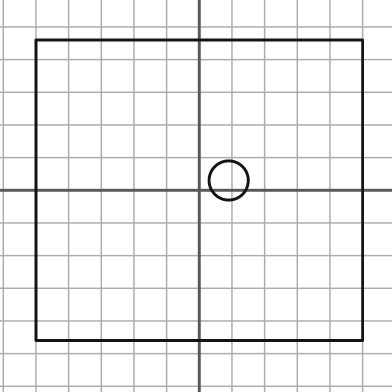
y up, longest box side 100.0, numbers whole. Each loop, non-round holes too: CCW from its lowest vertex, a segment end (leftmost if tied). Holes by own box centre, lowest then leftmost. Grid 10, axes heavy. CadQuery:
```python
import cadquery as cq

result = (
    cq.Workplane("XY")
    .moveTo(-50.0, -46.0)
    .lineTo(50.0, -46.0)
    .lineTo(50.0, 46.0)
    .lineTo(-50.0, 46.0)
    .close()
    .moveTo(9.0, 3.0)
    .circle(6.0)
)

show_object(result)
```